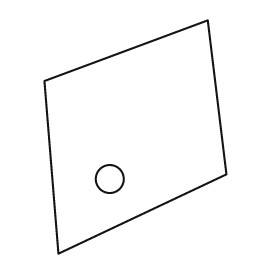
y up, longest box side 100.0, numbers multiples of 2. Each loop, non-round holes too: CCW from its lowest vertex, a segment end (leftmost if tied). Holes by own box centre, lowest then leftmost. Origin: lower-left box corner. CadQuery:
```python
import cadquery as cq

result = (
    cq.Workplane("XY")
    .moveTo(6.0, 0.0)
    .lineTo(78.0, 34.0)
    .lineTo(70.0, 100.0)
    .lineTo(0.0, 74.0)
    .close()
    .moveTo(28.0, 32.0)
    .circle(6.0)
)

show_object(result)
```